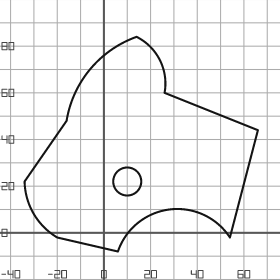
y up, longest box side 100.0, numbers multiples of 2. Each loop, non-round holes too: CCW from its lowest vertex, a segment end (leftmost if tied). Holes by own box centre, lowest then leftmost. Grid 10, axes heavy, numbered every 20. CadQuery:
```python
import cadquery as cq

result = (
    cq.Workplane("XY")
    .moveTo(6.0, -8.0)
    .threePointArc((28.0, 10.0), (54.0, -2.0))
    .lineTo(66.0, 44.0)
    .lineTo(26.0, 60.0)
    .threePointArc((24.0, 74.0), (14.0, 84.0))
    .threePointArc((-6.0, 70.0), (-16.0, 48.0))
    .lineTo(-34.0, 22.0)
    .threePointArc((-30.0, 8.0), (-20.0, -2.0))
    .close()
    .moveTo(10.0, 22.0)
    .circle(6.0)
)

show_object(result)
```